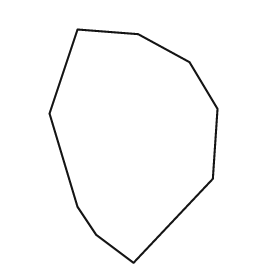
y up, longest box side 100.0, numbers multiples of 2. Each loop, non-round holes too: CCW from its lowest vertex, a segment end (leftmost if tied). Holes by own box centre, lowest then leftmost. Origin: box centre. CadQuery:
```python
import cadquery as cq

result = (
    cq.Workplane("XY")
    .moveTo(0.0, -50.0)
    .lineTo(34.0, -14.0)
    .lineTo(36.0, 16.0)
    .lineTo(24.0, 36.0)
    .lineTo(2.0, 48.0)
    .lineTo(-24.0, 50.0)
    .lineTo(-36.0, 14.0)
    .lineTo(-24.0, -26.0)
    .lineTo(-16.0, -38.0)
    .close()
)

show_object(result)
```